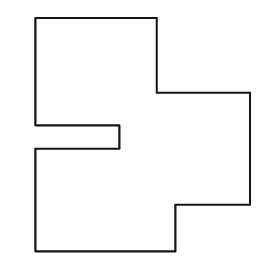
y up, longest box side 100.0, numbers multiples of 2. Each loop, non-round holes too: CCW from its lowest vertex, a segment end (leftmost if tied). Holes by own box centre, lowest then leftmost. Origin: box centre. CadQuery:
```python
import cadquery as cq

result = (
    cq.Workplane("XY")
    .moveTo(-46.0, -50.0)
    .lineTo(14.0, -50.0)
    .lineTo(14.0, -30.0)
    .lineTo(46.0, -30.0)
    .lineTo(46.0, 18.0)
    .lineTo(6.0, 18.0)
    .lineTo(6.0, 50.0)
    .lineTo(-46.0, 50.0)
    .lineTo(-46.0, 4.0)
    .lineTo(-10.0, 4.0)
    .lineTo(-10.0, -6.0)
    .lineTo(-46.0, -6.0)
    .close()
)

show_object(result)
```